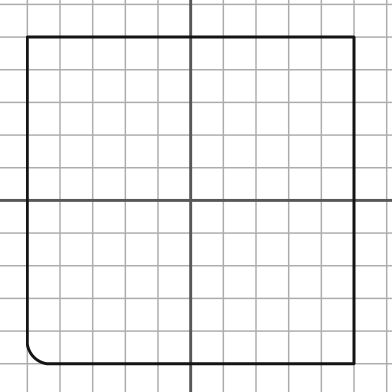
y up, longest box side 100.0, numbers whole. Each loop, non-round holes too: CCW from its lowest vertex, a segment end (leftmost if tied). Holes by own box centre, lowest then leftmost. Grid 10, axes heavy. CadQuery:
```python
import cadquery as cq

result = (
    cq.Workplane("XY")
    .moveTo(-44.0, -50.0)
    .lineTo(50.0, -50.0)
    .lineTo(50.0, 50.0)
    .lineTo(-50.0, 50.0)
    .lineTo(-50.0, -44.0)
    .threePointArc((-48.0, -48.0), (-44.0, -50.0))
    .close()
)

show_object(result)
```